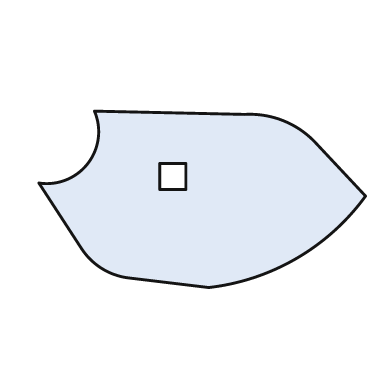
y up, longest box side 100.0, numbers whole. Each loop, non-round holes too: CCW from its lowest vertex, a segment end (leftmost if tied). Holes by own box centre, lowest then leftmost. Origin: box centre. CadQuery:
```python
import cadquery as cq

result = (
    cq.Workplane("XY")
    .moveTo(2.0, -27.0)
    .threePointArc((29.0, -18.0), (50.0, 1.0))
    .lineTo(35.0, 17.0)
    .threePointArc((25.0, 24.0), (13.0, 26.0))
    .lineTo(-33.0, 27.0)
    .threePointArc((-35.0, 11.0), (-50.0, 5.0))
    .lineTo(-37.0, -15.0)
    .threePointArc((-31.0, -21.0), (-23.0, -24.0))
    .close()
    .moveTo(-13.0, 3.0)
    .lineTo(-5.0, 3.0)
    .lineTo(-5.0, 11.0)
    .lineTo(-13.0, 11.0)
    .close()
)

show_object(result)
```